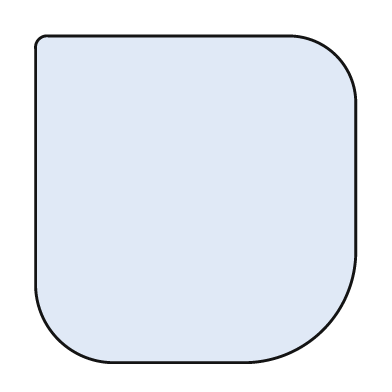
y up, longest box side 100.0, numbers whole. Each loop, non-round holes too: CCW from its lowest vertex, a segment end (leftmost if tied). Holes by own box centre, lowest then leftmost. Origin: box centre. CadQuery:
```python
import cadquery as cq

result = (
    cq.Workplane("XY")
    .moveTo(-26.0, -50.0)
    .lineTo(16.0, -50.0)
    .threePointArc((39.0, -40.0), (49.0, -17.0))
    .lineTo(49.0, 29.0)
    .threePointArc((43.0, 44.0), (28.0, 50.0))
    .lineTo(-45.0, 50.0)
    .threePointArc((-48.0, 49.0), (-49.0, 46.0))
    .lineTo(-49.0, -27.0)
    .threePointArc((-42.0, -43.0), (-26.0, -50.0))
    .close()
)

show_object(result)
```